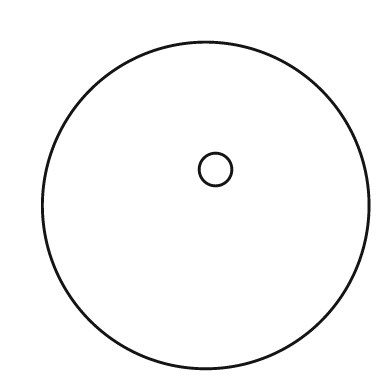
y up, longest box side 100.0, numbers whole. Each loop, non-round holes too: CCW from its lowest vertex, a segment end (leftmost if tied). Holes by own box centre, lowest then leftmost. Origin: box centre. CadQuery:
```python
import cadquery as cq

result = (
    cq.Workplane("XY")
    .moveTo(0.0, 0.0)
    .circle(50.0)
    .moveTo(3.0, 11.0)
    .circle(5.0)
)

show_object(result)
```